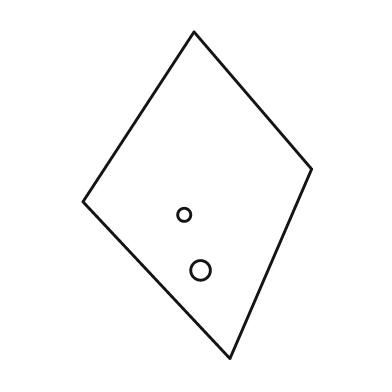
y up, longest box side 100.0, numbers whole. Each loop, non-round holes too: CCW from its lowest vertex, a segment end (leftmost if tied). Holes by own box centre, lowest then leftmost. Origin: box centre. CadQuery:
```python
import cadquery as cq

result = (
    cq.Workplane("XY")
    .moveTo(10.0, -50.0)
    .lineTo(35.0, 8.0)
    .lineTo(-1.0, 50.0)
    .lineTo(-35.0, -2.0)
    .close()
    .moveTo(1.0, -23.0)
    .circle(3.0)
    .moveTo(-4.0, -6.0)
    .circle(2.0)
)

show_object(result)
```